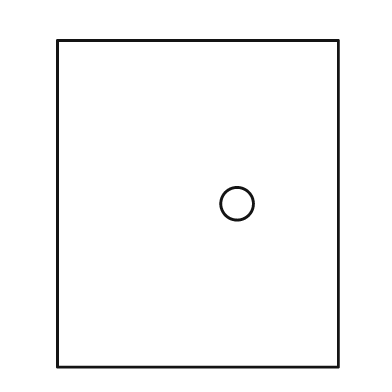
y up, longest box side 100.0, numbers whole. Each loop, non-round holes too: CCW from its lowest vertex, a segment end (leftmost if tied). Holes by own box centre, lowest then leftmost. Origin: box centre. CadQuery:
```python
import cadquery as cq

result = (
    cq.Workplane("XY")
    .moveTo(-43.0, -50.0)
    .lineTo(43.0, -50.0)
    .lineTo(43.0, 50.0)
    .lineTo(-43.0, 50.0)
    .close()
    .moveTo(12.0, 0.0)
    .circle(5.0)
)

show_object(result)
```